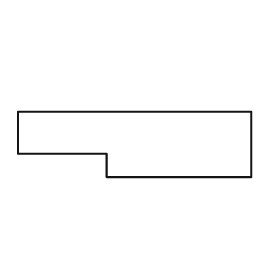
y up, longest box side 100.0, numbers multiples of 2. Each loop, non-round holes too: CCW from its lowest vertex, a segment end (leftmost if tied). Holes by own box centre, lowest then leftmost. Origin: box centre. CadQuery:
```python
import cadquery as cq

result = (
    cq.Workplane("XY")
    .moveTo(-12.0, -14.0)
    .lineTo(50.0, -14.0)
    .lineTo(50.0, 14.0)
    .lineTo(-50.0, 14.0)
    .lineTo(-50.0, -4.0)
    .lineTo(-12.0, -4.0)
    .close()
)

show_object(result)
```